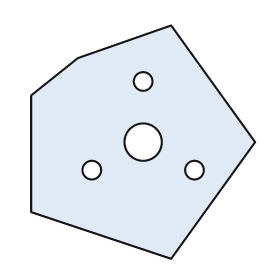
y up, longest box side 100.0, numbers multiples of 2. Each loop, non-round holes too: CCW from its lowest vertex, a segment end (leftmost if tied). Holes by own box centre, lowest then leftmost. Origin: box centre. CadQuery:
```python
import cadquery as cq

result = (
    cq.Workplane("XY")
    .moveTo(12.0, -50.0)
    .lineTo(48.0, 0.0)
    .lineTo(12.0, 50.0)
    .lineTo(-28.0, 36.0)
    .lineTo(-48.0, 20.0)
    .lineTo(-48.0, -30.0)
    .close()
    .moveTo(-22.0, -12.0)
    .circle(4.0)
    .moveTo(22.0, -12.0)
    .circle(4.0)
    .moveTo(0.0, 0.0)
    .circle(8.0)
    .moveTo(0.0, 26.0)
    .circle(4.0)
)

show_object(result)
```